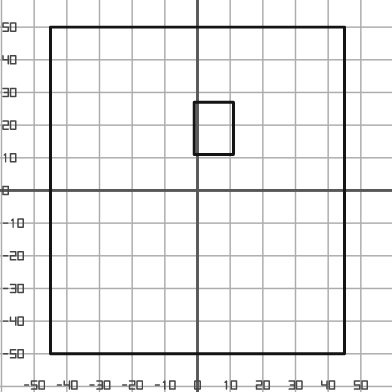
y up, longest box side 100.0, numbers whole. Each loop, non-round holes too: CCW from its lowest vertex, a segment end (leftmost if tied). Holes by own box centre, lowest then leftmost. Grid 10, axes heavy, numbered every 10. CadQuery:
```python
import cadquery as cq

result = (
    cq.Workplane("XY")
    .moveTo(-45.0, -50.0)
    .lineTo(45.0, -50.0)
    .lineTo(45.0, 50.0)
    .lineTo(-45.0, 50.0)
    .close()
    .moveTo(-1.0, 11.0)
    .lineTo(11.0, 11.0)
    .lineTo(11.0, 27.0)
    .lineTo(-1.0, 27.0)
    .close()
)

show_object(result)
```